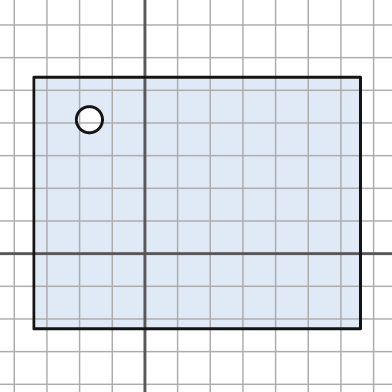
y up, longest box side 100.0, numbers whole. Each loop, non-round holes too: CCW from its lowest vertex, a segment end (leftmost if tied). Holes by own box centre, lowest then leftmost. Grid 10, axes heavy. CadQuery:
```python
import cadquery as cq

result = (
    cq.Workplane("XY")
    .moveTo(-34.0, -23.0)
    .lineTo(66.0, -23.0)
    .lineTo(66.0, 54.0)
    .lineTo(-34.0, 54.0)
    .close()
    .moveTo(-17.0, 41.0)
    .circle(4.0)
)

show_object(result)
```